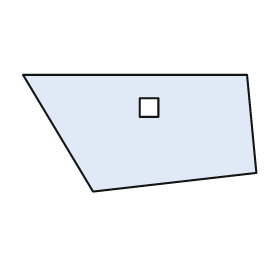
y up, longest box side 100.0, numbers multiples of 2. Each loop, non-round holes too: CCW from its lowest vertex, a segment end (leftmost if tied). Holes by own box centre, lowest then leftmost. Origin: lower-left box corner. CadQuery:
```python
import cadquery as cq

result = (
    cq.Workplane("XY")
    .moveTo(30.0, 0.0)
    .lineTo(100.0, 8.0)
    .lineTo(96.0, 50.0)
    .lineTo(0.0, 50.0)
    .close()
    .moveTo(50.0, 32.0)
    .lineTo(58.0, 32.0)
    .lineTo(58.0, 40.0)
    .lineTo(50.0, 40.0)
    .close()
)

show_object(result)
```